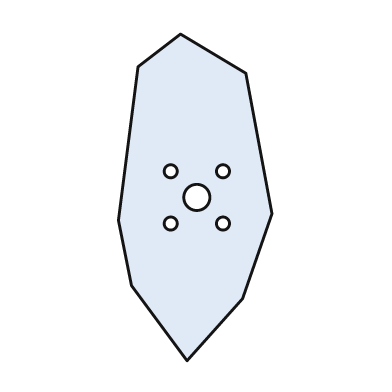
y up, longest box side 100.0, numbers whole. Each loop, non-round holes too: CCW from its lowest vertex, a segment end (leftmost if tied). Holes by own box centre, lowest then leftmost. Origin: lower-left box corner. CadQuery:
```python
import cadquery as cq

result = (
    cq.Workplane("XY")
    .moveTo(21.0, 0.0)
    .lineTo(38.0, 19.0)
    .lineTo(47.0, 45.0)
    .lineTo(39.0, 88.0)
    .lineTo(19.0, 100.0)
    .lineTo(6.0, 90.0)
    .lineTo(0.0, 43.0)
    .lineTo(4.0, 23.0)
    .close()
    .moveTo(16.0, 42.0)
    .circle(2.0)
    .moveTo(32.0, 42.0)
    .circle(2.0)
    .moveTo(24.0, 50.0)
    .circle(4.0)
    .moveTo(16.0, 58.0)
    .circle(2.0)
    .moveTo(32.0, 58.0)
    .circle(2.0)
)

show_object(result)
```